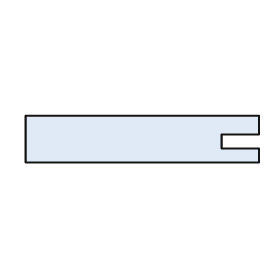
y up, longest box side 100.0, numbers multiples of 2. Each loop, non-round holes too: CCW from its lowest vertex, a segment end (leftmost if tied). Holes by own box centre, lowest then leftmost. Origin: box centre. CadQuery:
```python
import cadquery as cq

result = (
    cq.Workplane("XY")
    .moveTo(-50.0, -10.0)
    .lineTo(50.0, -10.0)
    .lineTo(50.0, -4.0)
    .lineTo(34.0, -4.0)
    .lineTo(34.0, 2.0)
    .lineTo(50.0, 2.0)
    .lineTo(50.0, 10.0)
    .lineTo(-50.0, 10.0)
    .close()
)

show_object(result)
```